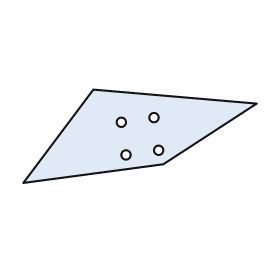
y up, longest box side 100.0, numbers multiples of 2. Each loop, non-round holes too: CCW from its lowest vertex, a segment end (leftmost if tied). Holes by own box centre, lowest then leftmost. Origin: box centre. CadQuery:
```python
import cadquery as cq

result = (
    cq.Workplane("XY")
    .moveTo(-50.0, -20.0)
    .lineTo(10.0, -12.0)
    .lineTo(50.0, 14.0)
    .lineTo(-20.0, 20.0)
    .close()
    .moveTo(-6.0, -8.0)
    .circle(2.0)
    .moveTo(8.0, -6.0)
    .circle(2.0)
    .moveTo(-8.0, 6.0)
    .circle(2.0)
    .moveTo(6.0, 8.0)
    .circle(2.0)
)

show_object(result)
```